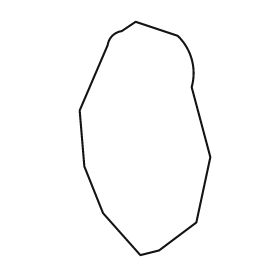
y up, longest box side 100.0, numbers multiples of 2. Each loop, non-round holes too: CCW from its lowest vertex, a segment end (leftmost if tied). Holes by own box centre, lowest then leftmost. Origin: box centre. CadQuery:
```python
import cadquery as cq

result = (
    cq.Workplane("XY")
    .moveTo(-2.0, -50.0)
    .lineTo(6.0, -48.0)
    .lineTo(22.0, -36.0)
    .lineTo(28.0, -8.0)
    .lineTo(20.0, 22.0)
    .threePointArc((20.0, 34.0), (14.0, 44.0))
    .lineTo(-4.0, 50.0)
    .lineTo(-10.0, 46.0)
    .threePointArc((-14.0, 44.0), (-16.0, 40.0))
    .lineTo(-28.0, 12.0)
    .lineTo(-26.0, -12.0)
    .lineTo(-18.0, -32.0)
    .close()
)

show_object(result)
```